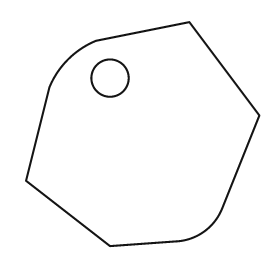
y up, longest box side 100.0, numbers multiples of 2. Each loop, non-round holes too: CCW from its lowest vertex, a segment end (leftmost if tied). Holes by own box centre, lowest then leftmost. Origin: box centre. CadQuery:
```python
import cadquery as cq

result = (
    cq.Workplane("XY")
    .moveTo(-14.0, -48.0)
    .lineTo(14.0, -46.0)
    .threePointArc((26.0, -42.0), (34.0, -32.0))
    .lineTo(50.0, 8.0)
    .lineTo(20.0, 48.0)
    .lineTo(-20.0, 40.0)
    .threePointArc((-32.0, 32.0), (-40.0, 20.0))
    .lineTo(-50.0, -20.0)
    .close()
    .moveTo(-14.0, 24.0)
    .circle(8.0)
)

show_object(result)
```